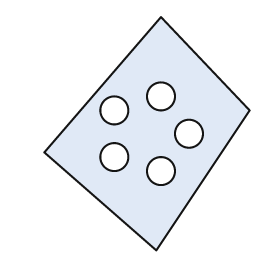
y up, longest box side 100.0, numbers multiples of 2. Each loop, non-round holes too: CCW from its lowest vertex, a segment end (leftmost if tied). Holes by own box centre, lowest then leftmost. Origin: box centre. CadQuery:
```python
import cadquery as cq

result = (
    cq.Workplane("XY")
    .moveTo(4.0, -50.0)
    .lineTo(44.0, 10.0)
    .lineTo(6.0, 50.0)
    .lineTo(-44.0, -8.0)
    .close()
    .moveTo(6.0, -16.0)
    .circle(6.0)
    .moveTo(-14.0, -10.0)
    .circle(6.0)
    .moveTo(18.0, 0.0)
    .circle(6.0)
    .moveTo(-14.0, 10.0)
    .circle(6.0)
    .moveTo(6.0, 16.0)
    .circle(6.0)
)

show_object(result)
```